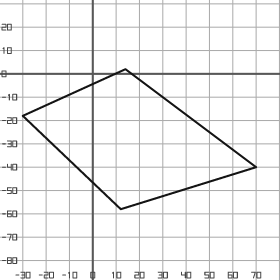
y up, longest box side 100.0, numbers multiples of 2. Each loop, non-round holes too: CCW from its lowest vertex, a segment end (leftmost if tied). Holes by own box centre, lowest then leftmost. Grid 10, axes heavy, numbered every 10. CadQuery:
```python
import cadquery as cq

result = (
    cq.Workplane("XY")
    .moveTo(12.0, -58.0)
    .lineTo(70.0, -40.0)
    .lineTo(14.0, 2.0)
    .lineTo(-30.0, -18.0)
    .close()
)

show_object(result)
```